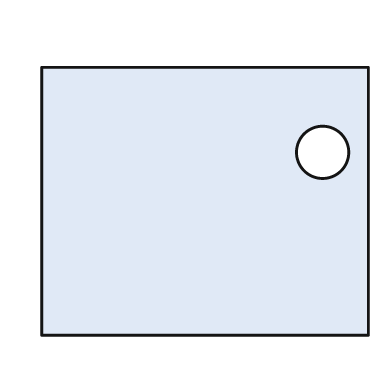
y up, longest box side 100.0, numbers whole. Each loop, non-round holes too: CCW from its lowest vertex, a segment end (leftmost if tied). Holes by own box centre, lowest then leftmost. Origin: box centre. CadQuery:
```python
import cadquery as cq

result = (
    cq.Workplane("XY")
    .moveTo(-50.0, -41.0)
    .lineTo(50.0, -41.0)
    .lineTo(50.0, 41.0)
    .lineTo(-50.0, 41.0)
    .close()
    .moveTo(36.0, 15.0)
    .circle(8.0)
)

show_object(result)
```